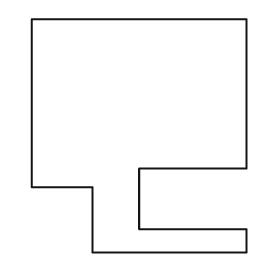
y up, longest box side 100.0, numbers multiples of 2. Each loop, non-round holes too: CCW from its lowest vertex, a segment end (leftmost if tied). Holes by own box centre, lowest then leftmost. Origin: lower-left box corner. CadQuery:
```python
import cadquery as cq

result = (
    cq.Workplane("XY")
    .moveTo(26.0, 0.0)
    .lineTo(92.0, 0.0)
    .lineTo(92.0, 10.0)
    .lineTo(46.0, 10.0)
    .lineTo(46.0, 36.0)
    .lineTo(92.0, 36.0)
    .lineTo(92.0, 100.0)
    .lineTo(0.0, 100.0)
    .lineTo(0.0, 28.0)
    .lineTo(26.0, 28.0)
    .close()
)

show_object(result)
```